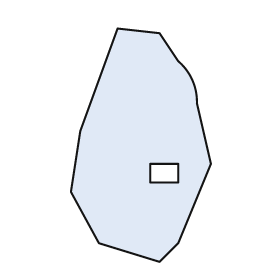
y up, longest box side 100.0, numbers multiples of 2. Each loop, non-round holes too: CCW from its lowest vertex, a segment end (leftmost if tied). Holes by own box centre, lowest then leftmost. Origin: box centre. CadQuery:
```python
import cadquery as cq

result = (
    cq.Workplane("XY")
    .moveTo(8.0, -50.0)
    .lineTo(16.0, -42.0)
    .lineTo(30.0, -8.0)
    .lineTo(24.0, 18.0)
    .threePointArc((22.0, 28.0), (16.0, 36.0))
    .lineTo(8.0, 48.0)
    .lineTo(-10.0, 50.0)
    .lineTo(-26.0, 6.0)
    .lineTo(-30.0, -20.0)
    .lineTo(-18.0, -42.0)
    .close()
    .moveTo(4.0, -16.0)
    .lineTo(16.0, -16.0)
    .lineTo(16.0, -8.0)
    .lineTo(4.0, -8.0)
    .close()
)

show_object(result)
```